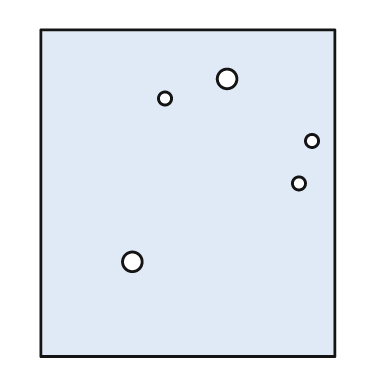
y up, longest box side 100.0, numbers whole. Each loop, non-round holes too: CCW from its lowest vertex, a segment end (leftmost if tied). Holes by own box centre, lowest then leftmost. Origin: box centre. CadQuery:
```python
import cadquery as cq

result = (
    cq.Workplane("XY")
    .moveTo(-45.0, -50.0)
    .lineTo(45.0, -50.0)
    .lineTo(45.0, 50.0)
    .lineTo(-45.0, 50.0)
    .close()
    .moveTo(-17.0, -21.0)
    .circle(3.0)
    .moveTo(34.0, 3.0)
    .circle(2.0)
    .moveTo(38.0, 16.0)
    .circle(2.0)
    .moveTo(-7.0, 29.0)
    .circle(2.0)
    .moveTo(12.0, 35.0)
    .circle(3.0)
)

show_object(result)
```